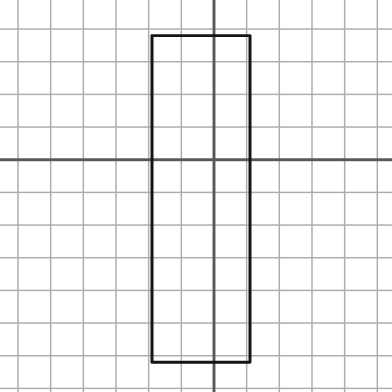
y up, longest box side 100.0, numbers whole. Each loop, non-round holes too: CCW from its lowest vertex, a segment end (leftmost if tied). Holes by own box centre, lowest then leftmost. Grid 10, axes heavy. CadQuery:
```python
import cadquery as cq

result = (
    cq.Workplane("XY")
    .moveTo(-19.0, -62.0)
    .lineTo(11.0, -62.0)
    .lineTo(11.0, 38.0)
    .lineTo(-19.0, 38.0)
    .close()
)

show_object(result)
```